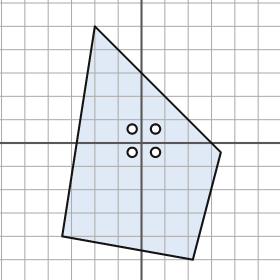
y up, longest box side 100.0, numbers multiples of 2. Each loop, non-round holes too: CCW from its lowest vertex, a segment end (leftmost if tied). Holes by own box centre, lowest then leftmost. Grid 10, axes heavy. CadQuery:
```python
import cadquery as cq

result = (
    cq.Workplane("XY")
    .moveTo(22.0, -50.0)
    .lineTo(34.0, -4.0)
    .lineTo(-20.0, 50.0)
    .lineTo(-34.0, -40.0)
    .close()
    .moveTo(-4.0, -4.0)
    .circle(2.0)
    .moveTo(6.0, -4.0)
    .circle(2.0)
    .moveTo(-4.0, 6.0)
    .circle(2.0)
    .moveTo(6.0, 6.0)
    .circle(2.0)
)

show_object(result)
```